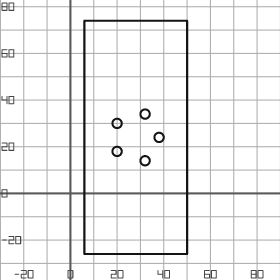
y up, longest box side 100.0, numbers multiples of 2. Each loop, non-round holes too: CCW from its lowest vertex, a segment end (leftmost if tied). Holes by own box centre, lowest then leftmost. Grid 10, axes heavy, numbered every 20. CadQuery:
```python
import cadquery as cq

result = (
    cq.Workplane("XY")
    .moveTo(6.0, -26.0)
    .lineTo(50.0, -26.0)
    .lineTo(50.0, 74.0)
    .lineTo(6.0, 74.0)
    .close()
    .moveTo(32.0, 14.0)
    .circle(2.0)
    .moveTo(20.0, 18.0)
    .circle(2.0)
    .moveTo(38.0, 24.0)
    .circle(2.0)
    .moveTo(20.0, 30.0)
    .circle(2.0)
    .moveTo(32.0, 34.0)
    .circle(2.0)
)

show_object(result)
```